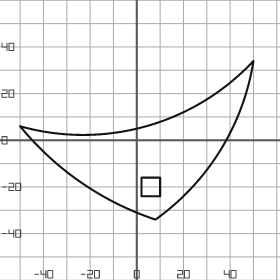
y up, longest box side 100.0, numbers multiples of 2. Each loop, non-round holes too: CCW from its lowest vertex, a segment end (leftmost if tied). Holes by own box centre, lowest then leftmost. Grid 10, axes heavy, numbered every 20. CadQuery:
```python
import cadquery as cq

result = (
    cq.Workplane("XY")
    .moveTo(8.0, -34.0)
    .threePointArc((36.0, -4.0), (50.0, 34.0))
    .threePointArc((4.0, 6.0), (-50.0, 6.0))
    .threePointArc((-24.0, -18.0), (8.0, -34.0))
    .close()
    .moveTo(2.0, -24.0)
    .lineTo(10.0, -24.0)
    .lineTo(10.0, -16.0)
    .lineTo(2.0, -16.0)
    .close()
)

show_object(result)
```